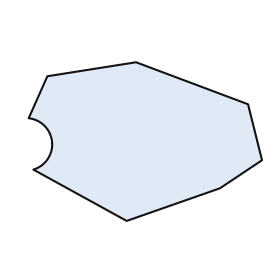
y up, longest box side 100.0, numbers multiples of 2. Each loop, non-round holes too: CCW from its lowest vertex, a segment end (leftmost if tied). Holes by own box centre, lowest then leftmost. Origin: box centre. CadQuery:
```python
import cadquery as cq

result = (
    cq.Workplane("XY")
    .moveTo(-8.0, -34.0)
    .lineTo(32.0, -20.0)
    .lineTo(50.0, -8.0)
    .lineTo(44.0, 16.0)
    .lineTo(-4.0, 34.0)
    .lineTo(-42.0, 28.0)
    .lineTo(-50.0, 10.0)
    .threePointArc((-40.0, 0.0), (-48.0, -12.0))
    .close()
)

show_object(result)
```